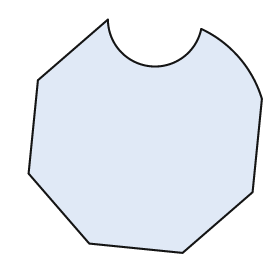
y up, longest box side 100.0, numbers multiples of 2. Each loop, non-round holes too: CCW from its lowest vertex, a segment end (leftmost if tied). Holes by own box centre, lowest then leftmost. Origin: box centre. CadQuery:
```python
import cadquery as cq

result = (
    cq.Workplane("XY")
    .moveTo(16.0, -50.0)
    .lineTo(46.0, -24.0)
    .lineTo(50.0, 16.0)
    .threePointArc((40.0, 34.0), (24.0, 46.0))
    .threePointArc((2.0, 30.0), (-16.0, 50.0))
    .lineTo(-46.0, 24.0)
    .lineTo(-50.0, -16.0)
    .lineTo(-24.0, -46.0)
    .close()
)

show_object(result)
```